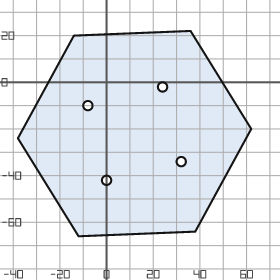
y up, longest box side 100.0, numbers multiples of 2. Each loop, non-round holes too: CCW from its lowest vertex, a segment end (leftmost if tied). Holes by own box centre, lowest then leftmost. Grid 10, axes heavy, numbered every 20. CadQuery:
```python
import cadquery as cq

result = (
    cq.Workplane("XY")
    .moveTo(-12.0, -66.0)
    .lineTo(38.0, -64.0)
    .lineTo(62.0, -20.0)
    .lineTo(36.0, 22.0)
    .lineTo(-14.0, 20.0)
    .lineTo(-38.0, -24.0)
    .close()
    .moveTo(0.0, -42.0)
    .circle(2.0)
    .moveTo(32.0, -34.0)
    .circle(2.0)
    .moveTo(-8.0, -10.0)
    .circle(2.0)
    .moveTo(24.0, -2.0)
    .circle(2.0)
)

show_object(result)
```